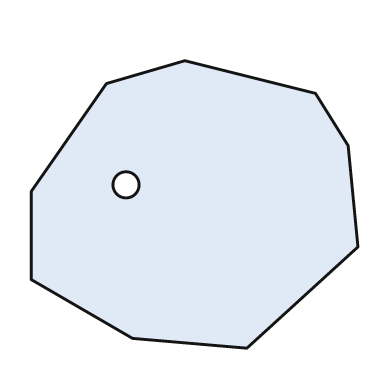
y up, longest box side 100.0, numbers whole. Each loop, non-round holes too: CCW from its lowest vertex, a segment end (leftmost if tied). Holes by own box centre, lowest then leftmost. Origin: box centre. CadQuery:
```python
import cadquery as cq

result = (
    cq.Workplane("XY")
    .moveTo(16.0, -44.0)
    .lineTo(50.0, -13.0)
    .lineTo(47.0, 18.0)
    .lineTo(37.0, 34.0)
    .lineTo(-3.0, 44.0)
    .lineTo(-27.0, 37.0)
    .lineTo(-50.0, 4.0)
    .lineTo(-50.0, -23.0)
    .lineTo(-19.0, -41.0)
    .close()
    .moveTo(-21.0, 6.0)
    .circle(4.0)
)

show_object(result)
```